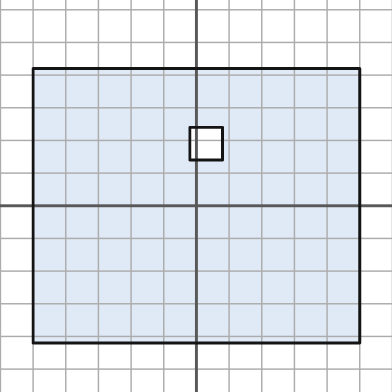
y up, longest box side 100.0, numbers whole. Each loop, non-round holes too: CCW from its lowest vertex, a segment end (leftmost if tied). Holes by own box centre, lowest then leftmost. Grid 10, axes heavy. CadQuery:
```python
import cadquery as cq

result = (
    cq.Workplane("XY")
    .moveTo(-50.0, -42.0)
    .lineTo(50.0, -42.0)
    .lineTo(50.0, 42.0)
    .lineTo(-50.0, 42.0)
    .close()
    .moveTo(-2.0, 14.0)
    .lineTo(8.0, 14.0)
    .lineTo(8.0, 24.0)
    .lineTo(-2.0, 24.0)
    .close()
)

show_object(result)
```